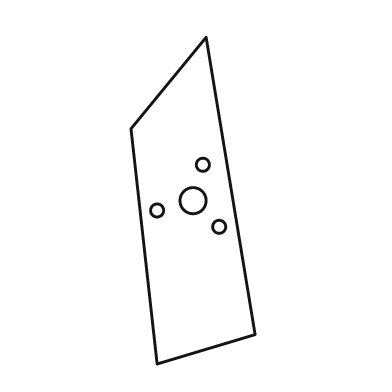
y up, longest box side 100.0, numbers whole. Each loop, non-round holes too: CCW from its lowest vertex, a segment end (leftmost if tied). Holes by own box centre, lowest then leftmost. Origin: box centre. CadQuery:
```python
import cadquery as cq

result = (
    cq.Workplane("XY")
    .moveTo(-11.0, -50.0)
    .lineTo(19.0, -41.0)
    .lineTo(4.0, 50.0)
    .lineTo(-19.0, 22.0)
    .close()
    .moveTo(8.0, -8.0)
    .circle(2.0)
    .moveTo(-11.0, -3.0)
    .circle(2.0)
    .moveTo(0.0, 0.0)
    .circle(4.0)
    .moveTo(3.0, 11.0)
    .circle(2.0)
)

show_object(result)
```